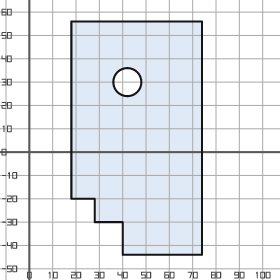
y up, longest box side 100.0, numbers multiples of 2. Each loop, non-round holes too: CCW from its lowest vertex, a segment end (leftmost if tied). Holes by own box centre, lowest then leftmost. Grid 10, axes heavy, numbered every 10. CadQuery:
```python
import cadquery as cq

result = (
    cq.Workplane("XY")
    .moveTo(40.0, -44.0)
    .lineTo(74.0, -44.0)
    .lineTo(74.0, 56.0)
    .lineTo(18.0, 56.0)
    .lineTo(18.0, -20.0)
    .lineTo(28.0, -20.0)
    .lineTo(28.0, -30.0)
    .lineTo(40.0, -30.0)
    .close()
    .moveTo(42.0, 30.0)
    .circle(6.0)
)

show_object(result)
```